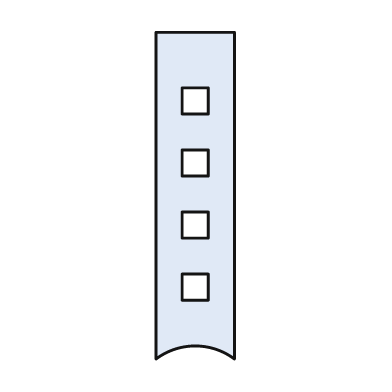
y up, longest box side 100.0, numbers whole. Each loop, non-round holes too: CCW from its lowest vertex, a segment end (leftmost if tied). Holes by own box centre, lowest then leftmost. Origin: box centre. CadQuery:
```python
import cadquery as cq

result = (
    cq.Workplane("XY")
    .moveTo(-12.0, -50.0)
    .threePointArc((0.0, -46.0), (12.0, -50.0))
    .lineTo(12.0, 50.0)
    .lineTo(-12.0, 50.0)
    .close()
    .moveTo(-4.0, -32.0)
    .lineTo(4.0, -32.0)
    .lineTo(4.0, -24.0)
    .lineTo(-4.0, -24.0)
    .close()
    .moveTo(-4.0, -13.0)
    .lineTo(4.0, -13.0)
    .lineTo(4.0, -5.0)
    .lineTo(-4.0, -5.0)
    .close()
    .moveTo(-4.0, 6.0)
    .lineTo(4.0, 6.0)
    .lineTo(4.0, 14.0)
    .lineTo(-4.0, 14.0)
    .close()
    .moveTo(-4.0, 25.0)
    .lineTo(4.0, 25.0)
    .lineTo(4.0, 33.0)
    .lineTo(-4.0, 33.0)
    .close()
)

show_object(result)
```